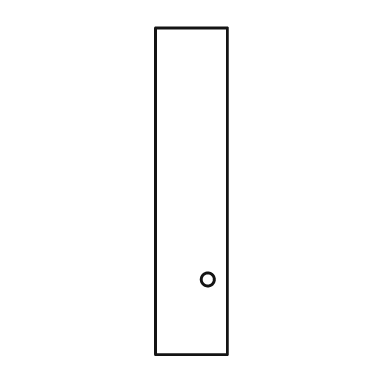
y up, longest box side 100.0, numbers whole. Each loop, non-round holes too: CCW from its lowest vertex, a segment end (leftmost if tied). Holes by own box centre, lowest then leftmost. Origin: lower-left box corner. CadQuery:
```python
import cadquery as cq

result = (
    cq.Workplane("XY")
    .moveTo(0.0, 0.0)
    .lineTo(22.0, 0.0)
    .lineTo(22.0, 100.0)
    .lineTo(0.0, 100.0)
    .close()
    .moveTo(16.0, 23.0)
    .circle(2.0)
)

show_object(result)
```